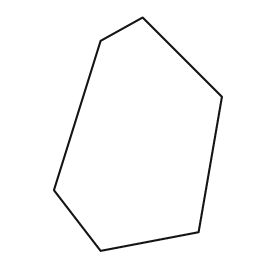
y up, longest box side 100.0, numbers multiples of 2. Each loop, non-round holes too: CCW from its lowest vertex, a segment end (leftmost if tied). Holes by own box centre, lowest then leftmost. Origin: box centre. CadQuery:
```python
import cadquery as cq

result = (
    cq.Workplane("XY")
    .moveTo(-16.0, -50.0)
    .lineTo(26.0, -42.0)
    .lineTo(36.0, 16.0)
    .lineTo(2.0, 50.0)
    .lineTo(-16.0, 40.0)
    .lineTo(-36.0, -24.0)
    .close()
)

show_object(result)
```